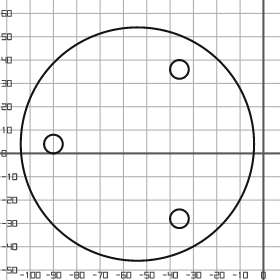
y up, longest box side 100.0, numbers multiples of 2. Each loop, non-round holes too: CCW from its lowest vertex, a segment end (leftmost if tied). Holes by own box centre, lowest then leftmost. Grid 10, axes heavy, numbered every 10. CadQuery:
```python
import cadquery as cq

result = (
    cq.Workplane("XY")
    .moveTo(-54.0, 4.0)
    .circle(50.0)
    .moveTo(-36.0, -28.0)
    .circle(4.0)
    .moveTo(-90.0, 4.0)
    .circle(4.0)
    .moveTo(-36.0, 36.0)
    .circle(4.0)
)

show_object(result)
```